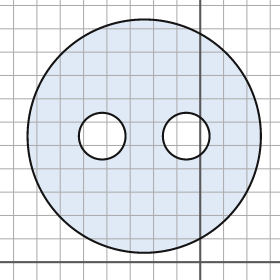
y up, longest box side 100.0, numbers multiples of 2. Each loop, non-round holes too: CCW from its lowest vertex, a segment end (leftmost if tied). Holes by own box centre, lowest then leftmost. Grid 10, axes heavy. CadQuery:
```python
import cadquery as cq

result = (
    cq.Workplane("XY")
    .moveTo(-24.0, 54.0)
    .circle(50.0)
    .moveTo(-42.0, 54.0)
    .circle(10.0)
    .moveTo(-6.0, 54.0)
    .circle(10.0)
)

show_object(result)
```